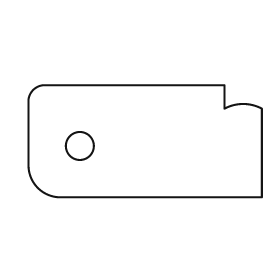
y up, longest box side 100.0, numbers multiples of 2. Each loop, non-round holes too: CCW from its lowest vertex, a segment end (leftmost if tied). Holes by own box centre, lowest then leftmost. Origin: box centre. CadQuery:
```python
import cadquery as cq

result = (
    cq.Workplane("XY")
    .moveTo(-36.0, -24.0)
    .lineTo(50.0, -24.0)
    .lineTo(50.0, 14.0)
    .threePointArc((42.0, 16.0), (34.0, 14.0))
    .lineTo(34.0, 24.0)
    .lineTo(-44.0, 24.0)
    .threePointArc((-48.0, 22.0), (-50.0, 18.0))
    .lineTo(-50.0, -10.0)
    .threePointArc((-46.0, -20.0), (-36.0, -24.0))
    .close()
    .moveTo(-28.0, -2.0)
    .circle(6.0)
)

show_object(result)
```